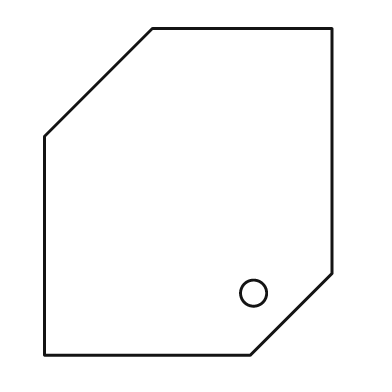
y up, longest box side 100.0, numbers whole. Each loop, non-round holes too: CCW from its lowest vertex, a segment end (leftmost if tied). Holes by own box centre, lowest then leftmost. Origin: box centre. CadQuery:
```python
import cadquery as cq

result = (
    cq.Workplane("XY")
    .moveTo(-44.0, -50.0)
    .lineTo(19.0, -50.0)
    .lineTo(44.0, -25.0)
    .lineTo(44.0, 50.0)
    .lineTo(-11.0, 50.0)
    .lineTo(-44.0, 17.0)
    .close()
    .moveTo(20.0, -31.0)
    .circle(4.0)
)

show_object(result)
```